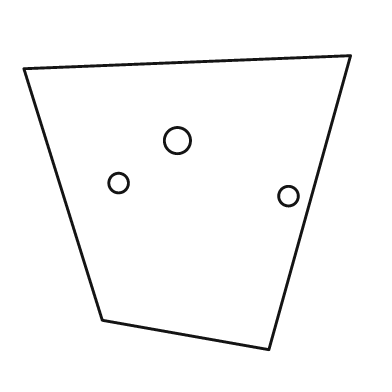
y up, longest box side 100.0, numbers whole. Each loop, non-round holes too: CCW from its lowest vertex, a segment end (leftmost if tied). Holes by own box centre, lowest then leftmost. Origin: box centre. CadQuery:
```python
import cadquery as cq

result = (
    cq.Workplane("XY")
    .moveTo(25.0, -45.0)
    .lineTo(50.0, 45.0)
    .lineTo(-50.0, 41.0)
    .lineTo(-26.0, -36.0)
    .close()
    .moveTo(31.0, 2.0)
    .circle(3.0)
    .moveTo(-21.0, 6.0)
    .circle(3.0)
    .moveTo(-3.0, 19.0)
    .circle(4.0)
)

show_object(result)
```